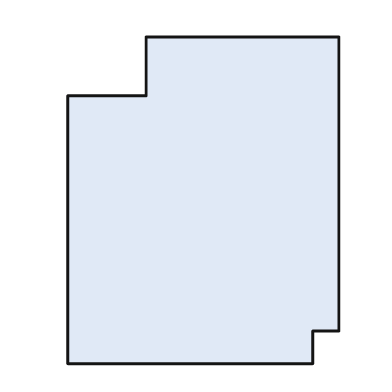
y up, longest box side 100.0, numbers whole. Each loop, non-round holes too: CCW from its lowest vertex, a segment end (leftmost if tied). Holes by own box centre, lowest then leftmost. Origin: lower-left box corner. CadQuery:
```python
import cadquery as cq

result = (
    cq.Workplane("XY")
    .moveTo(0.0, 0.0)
    .lineTo(75.0, 0.0)
    .lineTo(75.0, 10.0)
    .lineTo(83.0, 10.0)
    .lineTo(83.0, 100.0)
    .lineTo(24.0, 100.0)
    .lineTo(24.0, 82.0)
    .lineTo(0.0, 82.0)
    .close()
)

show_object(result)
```